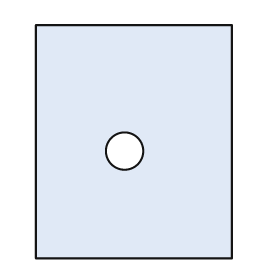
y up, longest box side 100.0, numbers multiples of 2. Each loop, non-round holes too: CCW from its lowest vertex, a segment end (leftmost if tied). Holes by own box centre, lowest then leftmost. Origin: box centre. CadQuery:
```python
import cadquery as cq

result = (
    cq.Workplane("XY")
    .moveTo(-42.0, -50.0)
    .lineTo(42.0, -50.0)
    .lineTo(42.0, 50.0)
    .lineTo(-42.0, 50.0)
    .close()
    .moveTo(-4.0, -4.0)
    .circle(8.0)
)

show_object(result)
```